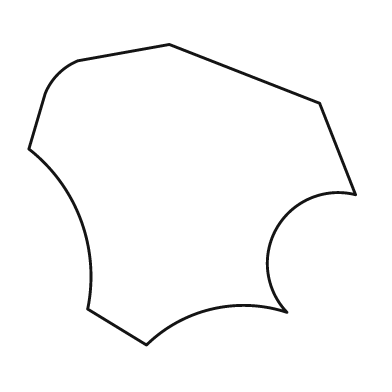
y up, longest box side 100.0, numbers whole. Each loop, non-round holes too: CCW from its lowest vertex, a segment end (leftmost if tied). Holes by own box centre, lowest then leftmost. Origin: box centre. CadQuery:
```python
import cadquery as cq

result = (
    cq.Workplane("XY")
    .moveTo(-14.0, -46.0)
    .threePointArc((6.0, -35.0), (29.0, -36.0))
    .threePointArc((26.0, -10.0), (50.0, 0.0))
    .lineTo(39.0, 28.0)
    .lineTo(-7.0, 46.0)
    .lineTo(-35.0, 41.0)
    .threePointArc((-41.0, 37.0), (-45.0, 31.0))
    .lineTo(-50.0, 14.0)
    .threePointArc((-34.0, -8.0), (-32.0, -35.0))
    .close()
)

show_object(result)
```